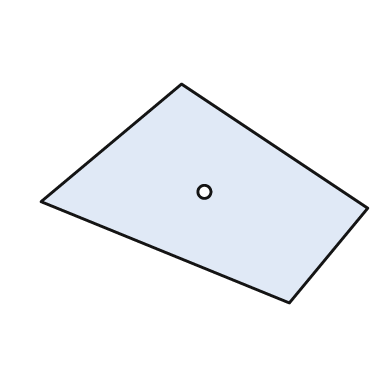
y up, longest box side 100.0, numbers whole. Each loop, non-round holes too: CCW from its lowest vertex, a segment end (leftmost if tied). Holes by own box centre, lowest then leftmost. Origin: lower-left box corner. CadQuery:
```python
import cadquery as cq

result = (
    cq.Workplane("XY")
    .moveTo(76.0, 0.0)
    .lineTo(100.0, 29.0)
    .lineTo(43.0, 67.0)
    .lineTo(0.0, 31.0)
    .close()
    .moveTo(50.0, 34.0)
    .circle(2.0)
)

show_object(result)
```